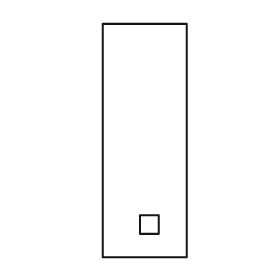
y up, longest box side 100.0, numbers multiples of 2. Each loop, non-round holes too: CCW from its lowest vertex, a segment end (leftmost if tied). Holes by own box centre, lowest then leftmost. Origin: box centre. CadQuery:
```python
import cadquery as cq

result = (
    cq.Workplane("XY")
    .moveTo(-18.0, -50.0)
    .lineTo(18.0, -50.0)
    .lineTo(18.0, 50.0)
    .lineTo(-18.0, 50.0)
    .close()
    .moveTo(-2.0, -40.0)
    .lineTo(6.0, -40.0)
    .lineTo(6.0, -32.0)
    .lineTo(-2.0, -32.0)
    .close()
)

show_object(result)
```